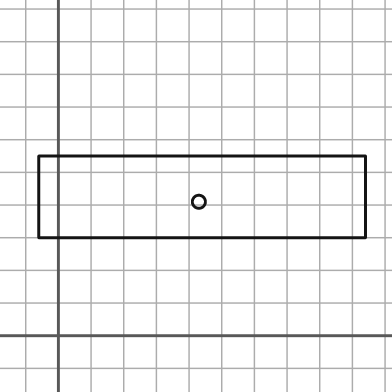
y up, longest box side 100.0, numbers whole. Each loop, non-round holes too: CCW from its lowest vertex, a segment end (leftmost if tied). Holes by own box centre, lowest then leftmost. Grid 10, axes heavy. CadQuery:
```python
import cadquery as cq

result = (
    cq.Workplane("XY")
    .moveTo(-6.0, 30.0)
    .lineTo(94.0, 30.0)
    .lineTo(94.0, 55.0)
    .lineTo(-6.0, 55.0)
    .close()
    .moveTo(43.0, 41.0)
    .circle(2.0)
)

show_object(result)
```